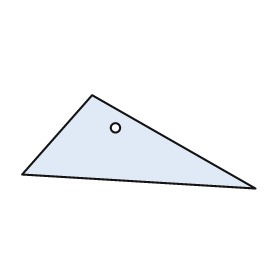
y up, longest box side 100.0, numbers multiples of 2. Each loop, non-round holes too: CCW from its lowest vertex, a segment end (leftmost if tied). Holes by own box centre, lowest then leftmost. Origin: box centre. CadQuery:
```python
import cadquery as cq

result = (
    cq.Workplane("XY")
    .moveTo(50.0, -20.0)
    .lineTo(-20.0, 20.0)
    .lineTo(-50.0, -14.0)
    .close()
    .moveTo(-10.0, 6.0)
    .circle(2.0)
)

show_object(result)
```